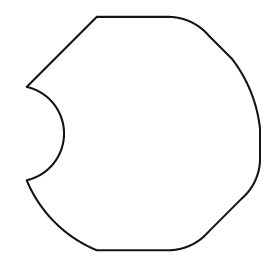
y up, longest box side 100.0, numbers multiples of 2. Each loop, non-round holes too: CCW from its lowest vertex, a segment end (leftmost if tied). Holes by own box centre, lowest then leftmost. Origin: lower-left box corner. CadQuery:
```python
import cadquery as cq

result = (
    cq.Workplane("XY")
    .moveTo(30.0, 0.0)
    .lineTo(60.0, 0.0)
    .threePointArc((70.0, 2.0), (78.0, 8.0))
    .lineTo(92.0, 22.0)
    .threePointArc((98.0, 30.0), (100.0, 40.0))
    .lineTo(100.0, 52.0)
    .threePointArc((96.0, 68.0), (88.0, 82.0))
    .lineTo(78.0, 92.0)
    .threePointArc((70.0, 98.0), (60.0, 100.0))
    .lineTo(30.0, 100.0)
    .lineTo(0.0, 70.0)
    .threePointArc((16.0, 50.0), (0.0, 30.0))
    .threePointArc((12.0, 12.0), (30.0, 0.0))
    .close()
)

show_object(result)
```